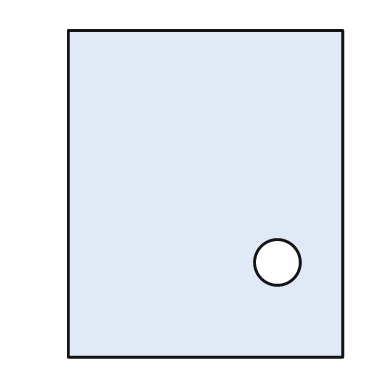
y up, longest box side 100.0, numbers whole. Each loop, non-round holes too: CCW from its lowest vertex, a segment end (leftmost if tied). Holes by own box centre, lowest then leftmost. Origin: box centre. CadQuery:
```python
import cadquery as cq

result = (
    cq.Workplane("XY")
    .moveTo(-42.0, -50.0)
    .lineTo(42.0, -50.0)
    .lineTo(42.0, 50.0)
    .lineTo(-42.0, 50.0)
    .close()
    .moveTo(22.0, -21.0)
    .circle(7.0)
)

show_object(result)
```